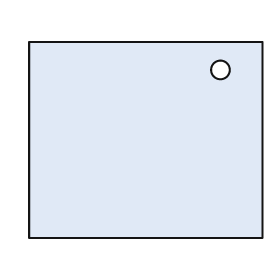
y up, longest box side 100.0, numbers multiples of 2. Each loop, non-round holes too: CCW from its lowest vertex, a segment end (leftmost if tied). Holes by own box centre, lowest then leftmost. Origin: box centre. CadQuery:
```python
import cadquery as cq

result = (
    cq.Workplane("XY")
    .moveTo(-50.0, -42.0)
    .lineTo(50.0, -42.0)
    .lineTo(50.0, 42.0)
    .lineTo(-50.0, 42.0)
    .close()
    .moveTo(32.0, 30.0)
    .circle(4.0)
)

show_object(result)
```